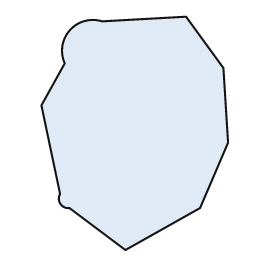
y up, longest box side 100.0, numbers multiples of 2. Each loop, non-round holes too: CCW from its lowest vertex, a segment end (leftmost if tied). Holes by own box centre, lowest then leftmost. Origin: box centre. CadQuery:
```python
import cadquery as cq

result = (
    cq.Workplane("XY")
    .moveTo(-4.0, -50.0)
    .lineTo(28.0, -32.0)
    .lineTo(40.0, -4.0)
    .lineTo(38.0, 28.0)
    .lineTo(22.0, 50.0)
    .lineTo(-14.0, 48.0)
    .threePointArc((-28.0, 44.0), (-30.0, 30.0))
    .lineTo(-40.0, 12.0)
    .lineTo(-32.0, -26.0)
    .threePointArc((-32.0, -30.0), (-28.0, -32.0))
    .close()
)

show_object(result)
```